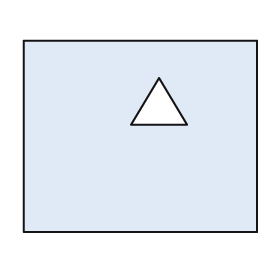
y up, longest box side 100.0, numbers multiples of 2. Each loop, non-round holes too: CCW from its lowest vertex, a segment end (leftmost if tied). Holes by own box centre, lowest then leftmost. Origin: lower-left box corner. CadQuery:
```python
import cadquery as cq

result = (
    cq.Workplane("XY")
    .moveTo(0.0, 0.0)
    .lineTo(100.0, 0.0)
    .lineTo(100.0, 82.0)
    .lineTo(0.0, 82.0)
    .close()
    .moveTo(46.0, 46.0)
    .lineTo(70.0, 46.0)
    .lineTo(58.0, 66.0)
    .close()
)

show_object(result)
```